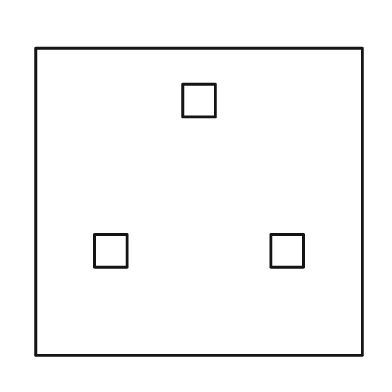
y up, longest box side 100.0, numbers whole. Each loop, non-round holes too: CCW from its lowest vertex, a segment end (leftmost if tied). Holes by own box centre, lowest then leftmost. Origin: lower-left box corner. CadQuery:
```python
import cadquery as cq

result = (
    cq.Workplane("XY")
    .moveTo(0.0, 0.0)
    .lineTo(100.0, 0.0)
    .lineTo(100.0, 94.0)
    .lineTo(0.0, 94.0)
    .close()
    .moveTo(18.0, 27.0)
    .lineTo(28.0, 27.0)
    .lineTo(28.0, 37.0)
    .lineTo(18.0, 37.0)
    .close()
    .moveTo(72.0, 27.0)
    .lineTo(82.0, 27.0)
    .lineTo(82.0, 37.0)
    .lineTo(72.0, 37.0)
    .close()
    .moveTo(45.0, 73.0)
    .lineTo(55.0, 73.0)
    .lineTo(55.0, 83.0)
    .lineTo(45.0, 83.0)
    .close()
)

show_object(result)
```